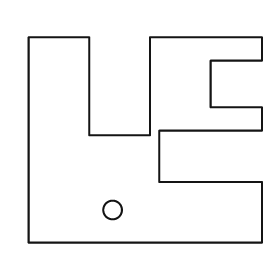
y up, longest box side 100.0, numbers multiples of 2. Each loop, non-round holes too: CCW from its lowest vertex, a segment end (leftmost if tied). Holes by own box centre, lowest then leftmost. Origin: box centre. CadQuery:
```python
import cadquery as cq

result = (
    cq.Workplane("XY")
    .moveTo(-50.0, -44.0)
    .lineTo(50.0, -44.0)
    .lineTo(50.0, -18.0)
    .lineTo(6.0, -18.0)
    .lineTo(6.0, 4.0)
    .lineTo(50.0, 4.0)
    .lineTo(50.0, 14.0)
    .lineTo(28.0, 14.0)
    .lineTo(28.0, 34.0)
    .lineTo(50.0, 34.0)
    .lineTo(50.0, 44.0)
    .lineTo(2.0, 44.0)
    .lineTo(2.0, 2.0)
    .lineTo(-24.0, 2.0)
    .lineTo(-24.0, 44.0)
    .lineTo(-50.0, 44.0)
    .close()
    .moveTo(-14.0, -30.0)
    .circle(4.0)
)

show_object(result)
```